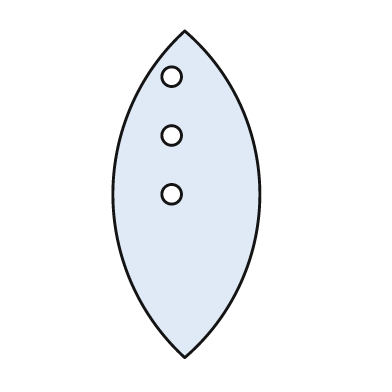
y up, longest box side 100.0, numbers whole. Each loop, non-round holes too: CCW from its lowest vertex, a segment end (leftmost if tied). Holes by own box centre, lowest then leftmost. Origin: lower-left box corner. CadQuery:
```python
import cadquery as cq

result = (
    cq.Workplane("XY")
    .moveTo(22.0, 0.0)
    .threePointArc((45.0, 50.0), (22.0, 100.0))
    .threePointArc((0.0, 50.0), (22.0, 0.0))
    .close()
    .moveTo(18.0, 50.0)
    .circle(3.0)
    .moveTo(18.0, 68.0)
    .circle(3.0)
    .moveTo(18.0, 86.0)
    .circle(3.0)
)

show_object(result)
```